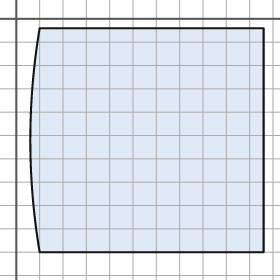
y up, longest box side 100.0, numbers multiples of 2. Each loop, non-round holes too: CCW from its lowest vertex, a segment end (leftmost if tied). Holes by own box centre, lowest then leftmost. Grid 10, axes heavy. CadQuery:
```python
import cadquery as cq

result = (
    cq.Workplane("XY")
    .moveTo(10.0, -100.0)
    .lineTo(106.0, -100.0)
    .lineTo(106.0, -4.0)
    .lineTo(10.0, -4.0)
    .threePointArc((6.0, -52.0), (10.0, -100.0))
    .close()
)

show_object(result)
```